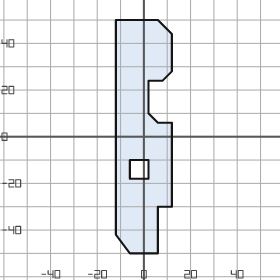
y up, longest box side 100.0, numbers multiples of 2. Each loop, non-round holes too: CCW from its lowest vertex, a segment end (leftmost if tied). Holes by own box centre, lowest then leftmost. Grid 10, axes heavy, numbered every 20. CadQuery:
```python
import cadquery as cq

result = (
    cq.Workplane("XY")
    .moveTo(-6.0, -50.0)
    .lineTo(6.0, -50.0)
    .lineTo(6.0, -30.0)
    .lineTo(12.0, -30.0)
    .lineTo(12.0, 6.0)
    .lineTo(6.0, 6.0)
    .lineTo(2.0, 10.0)
    .lineTo(2.0, 24.0)
    .lineTo(8.0, 24.0)
    .lineTo(12.0, 28.0)
    .lineTo(12.0, 44.0)
    .lineTo(6.0, 50.0)
    .lineTo(-12.0, 50.0)
    .lineTo(-12.0, -42.0)
    .close()
    .moveTo(-6.0, -18.0)
    .lineTo(2.0, -18.0)
    .lineTo(2.0, -10.0)
    .lineTo(-6.0, -10.0)
    .close()
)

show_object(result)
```